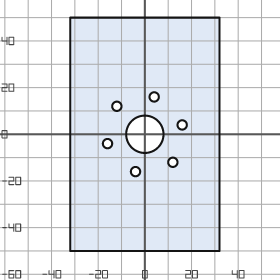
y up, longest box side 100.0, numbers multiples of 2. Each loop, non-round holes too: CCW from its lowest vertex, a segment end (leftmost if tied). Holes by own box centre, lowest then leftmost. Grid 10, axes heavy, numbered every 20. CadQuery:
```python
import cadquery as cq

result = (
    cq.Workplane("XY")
    .moveTo(-32.0, -50.0)
    .lineTo(32.0, -50.0)
    .lineTo(32.0, 50.0)
    .lineTo(-32.0, 50.0)
    .close()
    .moveTo(-4.0, -16.0)
    .circle(2.0)
    .moveTo(12.0, -12.0)
    .circle(2.0)
    .moveTo(-16.0, -4.0)
    .circle(2.0)
    .moveTo(0.0, 0.0)
    .circle(8.0)
    .moveTo(16.0, 4.0)
    .circle(2.0)
    .moveTo(-12.0, 12.0)
    .circle(2.0)
    .moveTo(4.0, 16.0)
    .circle(2.0)
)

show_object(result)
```